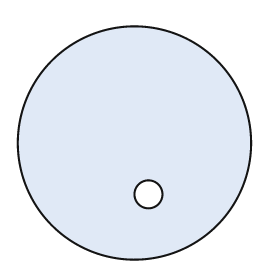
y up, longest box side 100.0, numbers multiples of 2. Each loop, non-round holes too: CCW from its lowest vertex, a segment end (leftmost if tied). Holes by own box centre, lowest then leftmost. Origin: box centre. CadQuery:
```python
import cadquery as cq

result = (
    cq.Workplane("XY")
    .moveTo(0.0, 0.0)
    .circle(50.0)
    .moveTo(6.0, -22.0)
    .circle(6.0)
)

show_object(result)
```